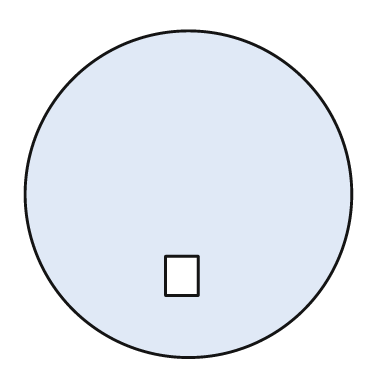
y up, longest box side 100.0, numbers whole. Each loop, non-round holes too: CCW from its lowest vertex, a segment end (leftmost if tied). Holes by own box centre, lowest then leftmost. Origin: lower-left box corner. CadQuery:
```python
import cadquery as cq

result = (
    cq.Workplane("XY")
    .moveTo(50.0, 50.0)
    .circle(50.0)
    .moveTo(43.0, 19.0)
    .lineTo(53.0, 19.0)
    .lineTo(53.0, 31.0)
    .lineTo(43.0, 31.0)
    .close()
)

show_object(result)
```